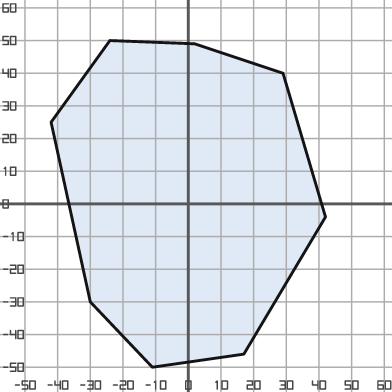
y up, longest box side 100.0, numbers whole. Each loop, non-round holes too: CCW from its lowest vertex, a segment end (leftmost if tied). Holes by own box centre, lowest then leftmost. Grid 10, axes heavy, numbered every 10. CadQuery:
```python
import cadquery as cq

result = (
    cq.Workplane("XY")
    .moveTo(-11.0, -50.0)
    .lineTo(17.0, -46.0)
    .lineTo(42.0, -4.0)
    .lineTo(29.0, 40.0)
    .lineTo(2.0, 49.0)
    .lineTo(-24.0, 50.0)
    .lineTo(-42.0, 25.0)
    .lineTo(-30.0, -30.0)
    .close()
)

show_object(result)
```